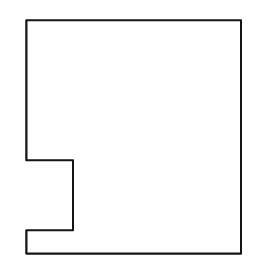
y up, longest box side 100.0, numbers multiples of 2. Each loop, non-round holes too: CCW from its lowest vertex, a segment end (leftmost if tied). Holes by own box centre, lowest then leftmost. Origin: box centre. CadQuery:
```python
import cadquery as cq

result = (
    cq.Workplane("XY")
    .moveTo(-46.0, -50.0)
    .lineTo(46.0, -50.0)
    .lineTo(46.0, 50.0)
    .lineTo(-46.0, 50.0)
    .lineTo(-46.0, -10.0)
    .lineTo(-26.0, -10.0)
    .lineTo(-26.0, -40.0)
    .lineTo(-46.0, -40.0)
    .close()
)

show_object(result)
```